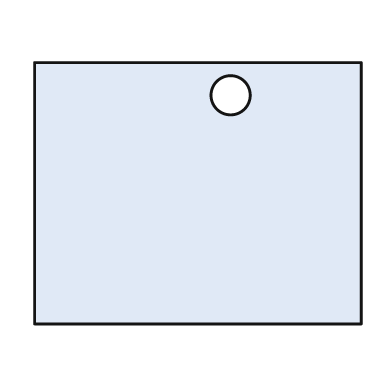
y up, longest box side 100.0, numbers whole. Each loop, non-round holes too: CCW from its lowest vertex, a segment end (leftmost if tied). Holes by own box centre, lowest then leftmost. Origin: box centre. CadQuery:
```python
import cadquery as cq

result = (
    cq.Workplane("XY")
    .moveTo(-50.0, -40.0)
    .lineTo(50.0, -40.0)
    .lineTo(50.0, 40.0)
    .lineTo(-50.0, 40.0)
    .close()
    .moveTo(10.0, 30.0)
    .circle(6.0)
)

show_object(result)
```